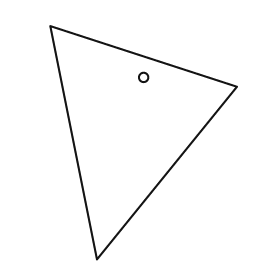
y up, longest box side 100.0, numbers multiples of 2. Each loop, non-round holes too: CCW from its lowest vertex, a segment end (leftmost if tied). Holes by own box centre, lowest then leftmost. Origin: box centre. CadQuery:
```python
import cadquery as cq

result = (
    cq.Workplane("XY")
    .moveTo(-20.0, -50.0)
    .lineTo(40.0, 24.0)
    .lineTo(-40.0, 50.0)
    .close()
    .moveTo(0.0, 28.0)
    .circle(2.0)
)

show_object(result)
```